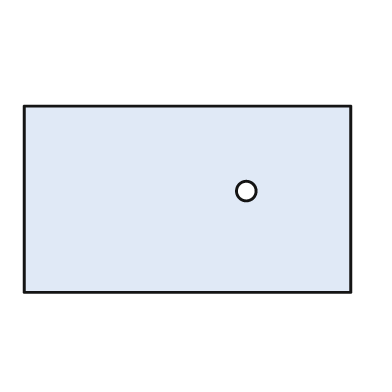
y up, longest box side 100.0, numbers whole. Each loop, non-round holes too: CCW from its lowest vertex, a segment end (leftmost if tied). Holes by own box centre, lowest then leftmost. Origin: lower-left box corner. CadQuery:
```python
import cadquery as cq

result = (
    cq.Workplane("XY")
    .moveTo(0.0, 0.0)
    .lineTo(100.0, 0.0)
    .lineTo(100.0, 57.0)
    .lineTo(0.0, 57.0)
    .close()
    .moveTo(68.0, 31.0)
    .circle(3.0)
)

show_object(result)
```